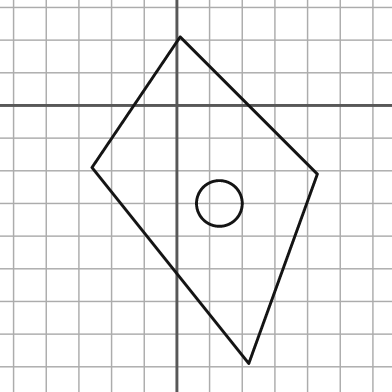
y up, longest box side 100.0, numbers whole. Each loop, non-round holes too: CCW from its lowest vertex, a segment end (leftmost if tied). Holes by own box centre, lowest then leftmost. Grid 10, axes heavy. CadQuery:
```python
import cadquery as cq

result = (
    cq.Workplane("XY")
    .moveTo(22.0, -79.0)
    .lineTo(43.0, -21.0)
    .lineTo(1.0, 21.0)
    .lineTo(-26.0, -19.0)
    .close()
    .moveTo(13.0, -30.0)
    .circle(7.0)
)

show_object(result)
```